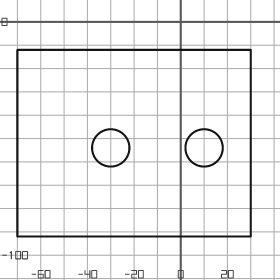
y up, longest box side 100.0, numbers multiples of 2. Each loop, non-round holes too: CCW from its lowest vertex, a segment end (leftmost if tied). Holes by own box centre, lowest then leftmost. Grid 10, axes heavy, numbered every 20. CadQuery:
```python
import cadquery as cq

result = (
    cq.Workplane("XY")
    .moveTo(-70.0, -92.0)
    .lineTo(30.0, -92.0)
    .lineTo(30.0, -12.0)
    .lineTo(-70.0, -12.0)
    .close()
    .moveTo(-30.0, -54.0)
    .circle(8.0)
    .moveTo(10.0, -54.0)
    .circle(8.0)
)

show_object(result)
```